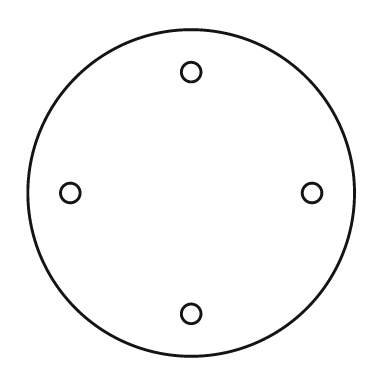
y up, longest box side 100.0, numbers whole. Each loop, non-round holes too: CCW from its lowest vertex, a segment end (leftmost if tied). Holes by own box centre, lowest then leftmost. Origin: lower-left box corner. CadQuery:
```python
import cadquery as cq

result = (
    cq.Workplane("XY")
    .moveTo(50.0, 50.0)
    .circle(50.0)
    .moveTo(50.0, 13.0)
    .circle(3.0)
    .moveTo(13.0, 50.0)
    .circle(3.0)
    .moveTo(87.0, 50.0)
    .circle(3.0)
    .moveTo(50.0, 87.0)
    .circle(3.0)
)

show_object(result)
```